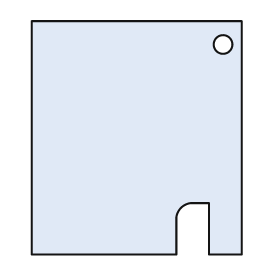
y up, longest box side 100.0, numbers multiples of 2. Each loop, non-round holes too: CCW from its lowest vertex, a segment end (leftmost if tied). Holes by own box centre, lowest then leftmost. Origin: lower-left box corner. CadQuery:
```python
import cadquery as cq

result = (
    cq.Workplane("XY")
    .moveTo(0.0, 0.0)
    .lineTo(62.0, 0.0)
    .lineTo(62.0, 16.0)
    .threePointArc((64.0, 20.0), (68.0, 22.0))
    .lineTo(76.0, 22.0)
    .lineTo(76.0, 0.0)
    .lineTo(90.0, 0.0)
    .lineTo(90.0, 100.0)
    .lineTo(0.0, 100.0)
    .close()
    .moveTo(82.0, 90.0)
    .circle(4.0)
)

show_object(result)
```